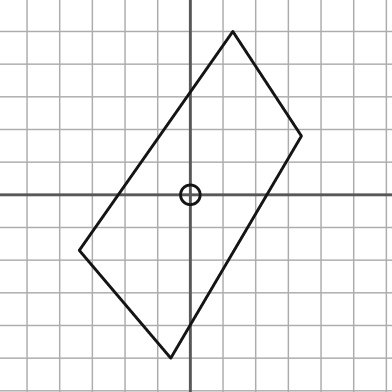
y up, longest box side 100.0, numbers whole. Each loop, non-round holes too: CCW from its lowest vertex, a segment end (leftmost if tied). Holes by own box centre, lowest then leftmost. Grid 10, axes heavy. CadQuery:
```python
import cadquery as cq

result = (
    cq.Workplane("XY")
    .moveTo(-6.0, -50.0)
    .lineTo(34.0, 18.0)
    .lineTo(13.0, 50.0)
    .lineTo(-34.0, -17.0)
    .close()
    .moveTo(0.0, 0.0)
    .circle(3.0)
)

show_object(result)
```